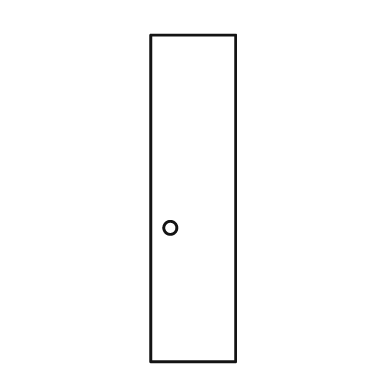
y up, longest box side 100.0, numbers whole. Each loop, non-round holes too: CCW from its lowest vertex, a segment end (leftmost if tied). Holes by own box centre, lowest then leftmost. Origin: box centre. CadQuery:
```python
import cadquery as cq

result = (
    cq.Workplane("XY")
    .moveTo(-13.0, -50.0)
    .lineTo(13.0, -50.0)
    .lineTo(13.0, 50.0)
    .lineTo(-13.0, 50.0)
    .close()
    .moveTo(-7.0, -9.0)
    .circle(2.0)
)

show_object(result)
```